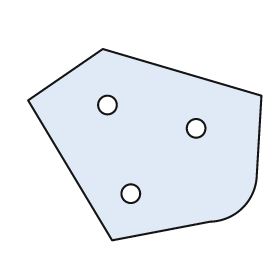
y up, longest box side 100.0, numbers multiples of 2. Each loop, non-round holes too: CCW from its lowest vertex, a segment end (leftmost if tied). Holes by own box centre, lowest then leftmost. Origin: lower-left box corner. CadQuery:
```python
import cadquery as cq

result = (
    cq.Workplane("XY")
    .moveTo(36.0, 0.0)
    .lineTo(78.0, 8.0)
    .threePointArc((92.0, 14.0), (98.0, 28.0))
    .lineTo(100.0, 62.0)
    .lineTo(32.0, 82.0)
    .lineTo(0.0, 60.0)
    .close()
    .moveTo(44.0, 20.0)
    .circle(4.0)
    .moveTo(72.0, 48.0)
    .circle(4.0)
    .moveTo(34.0, 58.0)
    .circle(4.0)
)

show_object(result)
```